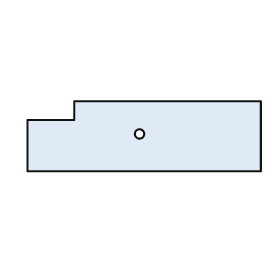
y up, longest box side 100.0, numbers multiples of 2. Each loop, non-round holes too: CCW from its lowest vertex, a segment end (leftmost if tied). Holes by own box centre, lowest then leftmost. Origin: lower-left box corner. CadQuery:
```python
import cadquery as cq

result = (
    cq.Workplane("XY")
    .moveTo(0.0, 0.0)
    .lineTo(100.0, 0.0)
    .lineTo(100.0, 30.0)
    .lineTo(20.0, 30.0)
    .lineTo(20.0, 22.0)
    .lineTo(0.0, 22.0)
    .close()
    .moveTo(48.0, 16.0)
    .circle(2.0)
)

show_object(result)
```